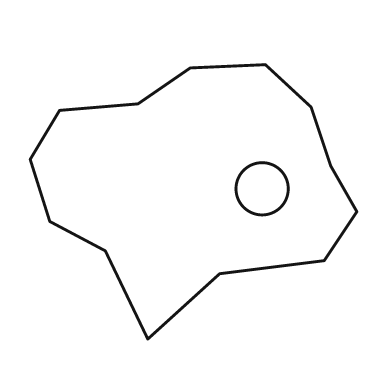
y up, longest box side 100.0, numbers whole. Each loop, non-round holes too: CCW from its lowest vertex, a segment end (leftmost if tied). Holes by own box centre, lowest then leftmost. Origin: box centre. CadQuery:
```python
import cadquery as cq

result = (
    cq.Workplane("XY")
    .moveTo(-14.0, -42.0)
    .lineTo(8.0, -22.0)
    .lineTo(40.0, -18.0)
    .lineTo(50.0, -3.0)
    .lineTo(42.0, 11.0)
    .lineTo(36.0, 29.0)
    .lineTo(22.0, 42.0)
    .lineTo(-1.0, 41.0)
    .lineTo(-17.0, 30.0)
    .lineTo(-41.0, 28.0)
    .lineTo(-50.0, 13.0)
    .lineTo(-44.0, -6.0)
    .lineTo(-27.0, -15.0)
    .close()
    .moveTo(21.0, 4.0)
    .circle(8.0)
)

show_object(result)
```